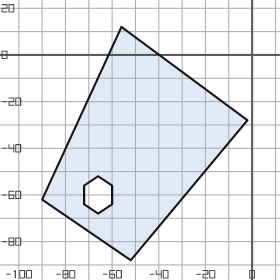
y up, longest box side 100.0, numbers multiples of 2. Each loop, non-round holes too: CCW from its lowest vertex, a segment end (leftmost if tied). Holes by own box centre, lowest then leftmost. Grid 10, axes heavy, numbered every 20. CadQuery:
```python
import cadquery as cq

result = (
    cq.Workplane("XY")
    .moveTo(-52.0, -88.0)
    .lineTo(-2.0, -28.0)
    .lineTo(-56.0, 12.0)
    .lineTo(-90.0, -62.0)
    .close()
    .moveTo(-66.0, -68.0)
    .lineTo(-60.0, -64.0)
    .lineTo(-60.0, -56.0)
    .lineTo(-66.0, -52.0)
    .lineTo(-72.0, -56.0)
    .lineTo(-72.0, -64.0)
    .close()
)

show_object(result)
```